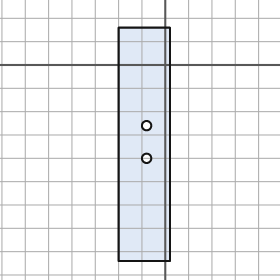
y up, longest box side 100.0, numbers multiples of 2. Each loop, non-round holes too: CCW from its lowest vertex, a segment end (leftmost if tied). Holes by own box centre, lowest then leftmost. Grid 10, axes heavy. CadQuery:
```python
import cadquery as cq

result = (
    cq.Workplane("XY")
    .moveTo(-20.0, -84.0)
    .lineTo(2.0, -84.0)
    .lineTo(2.0, 16.0)
    .lineTo(-20.0, 16.0)
    .close()
    .moveTo(-8.0, -40.0)
    .circle(2.0)
    .moveTo(-8.0, -26.0)
    .circle(2.0)
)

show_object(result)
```